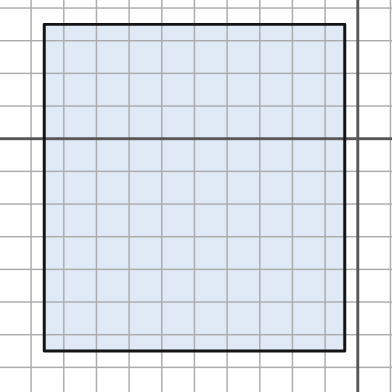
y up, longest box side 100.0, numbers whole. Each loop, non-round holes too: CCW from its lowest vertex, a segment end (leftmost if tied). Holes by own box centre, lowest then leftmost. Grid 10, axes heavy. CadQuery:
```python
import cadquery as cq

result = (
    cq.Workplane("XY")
    .moveTo(-96.0, -65.0)
    .lineTo(-4.0, -65.0)
    .lineTo(-4.0, 35.0)
    .lineTo(-96.0, 35.0)
    .close()
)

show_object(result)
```